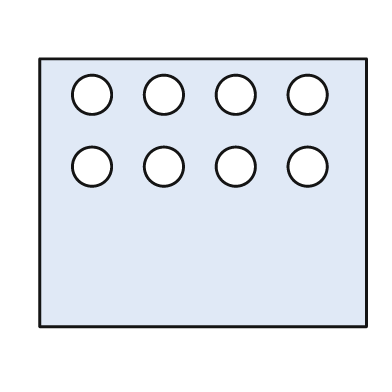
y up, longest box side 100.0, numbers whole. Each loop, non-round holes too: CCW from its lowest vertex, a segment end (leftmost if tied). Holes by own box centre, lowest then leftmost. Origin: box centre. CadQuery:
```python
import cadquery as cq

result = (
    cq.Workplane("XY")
    .moveTo(-50.0, -41.0)
    .lineTo(50.0, -41.0)
    .lineTo(50.0, 41.0)
    .lineTo(-50.0, 41.0)
    .close()
    .moveTo(-34.0, 8.0)
    .circle(6.0)
    .moveTo(-12.0, 8.0)
    .circle(6.0)
    .moveTo(10.0, 8.0)
    .circle(6.0)
    .moveTo(32.0, 8.0)
    .circle(6.0)
    .moveTo(-34.0, 30.0)
    .circle(6.0)
    .moveTo(-12.0, 30.0)
    .circle(6.0)
    .moveTo(10.0, 30.0)
    .circle(6.0)
    .moveTo(32.0, 30.0)
    .circle(6.0)
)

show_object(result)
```